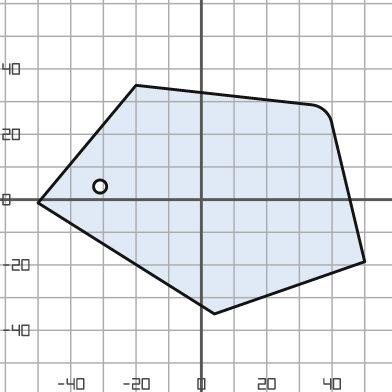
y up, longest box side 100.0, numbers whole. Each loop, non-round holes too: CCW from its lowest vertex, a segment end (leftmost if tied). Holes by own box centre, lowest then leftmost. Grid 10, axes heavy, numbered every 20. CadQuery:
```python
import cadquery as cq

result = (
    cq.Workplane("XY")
    .moveTo(4.0, -35.0)
    .lineTo(50.0, -19.0)
    .lineTo(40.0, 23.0)
    .threePointArc((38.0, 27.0), (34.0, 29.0))
    .lineTo(-20.0, 35.0)
    .lineTo(-50.0, -1.0)
    .close()
    .moveTo(-31.0, 4.0)
    .circle(2.0)
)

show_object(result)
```